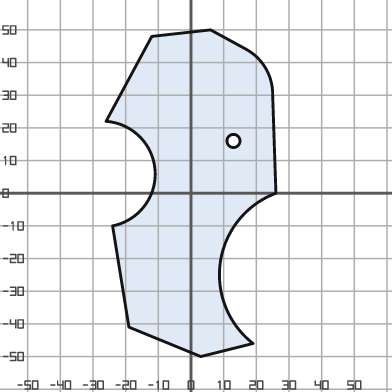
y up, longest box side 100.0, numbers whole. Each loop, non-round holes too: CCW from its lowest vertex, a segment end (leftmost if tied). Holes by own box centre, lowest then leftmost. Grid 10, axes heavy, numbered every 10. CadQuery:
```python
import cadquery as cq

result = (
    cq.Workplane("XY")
    .moveTo(3.0, -50.0)
    .lineTo(19.0, -46.0)
    .threePointArc((9.0, -21.0), (26.0, 0.0))
    .lineTo(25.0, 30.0)
    .threePointArc((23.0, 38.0), (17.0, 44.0))
    .lineTo(6.0, 50.0)
    .lineTo(-12.0, 48.0)
    .lineTo(-26.0, 22.0)
    .threePointArc((-11.0, 7.0), (-24.0, -10.0))
    .lineTo(-19.0, -41.0)
    .close()
    .moveTo(13.0, 16.0)
    .circle(2.0)
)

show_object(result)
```